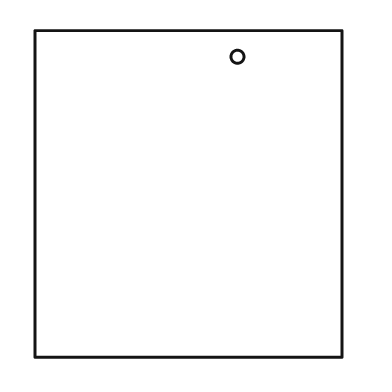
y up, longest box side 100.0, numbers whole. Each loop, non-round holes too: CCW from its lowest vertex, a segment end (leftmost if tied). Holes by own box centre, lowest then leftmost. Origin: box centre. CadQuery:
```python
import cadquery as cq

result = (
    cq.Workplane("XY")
    .moveTo(-47.0, -50.0)
    .lineTo(47.0, -50.0)
    .lineTo(47.0, 50.0)
    .lineTo(-47.0, 50.0)
    .close()
    .moveTo(15.0, 42.0)
    .circle(2.0)
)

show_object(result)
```